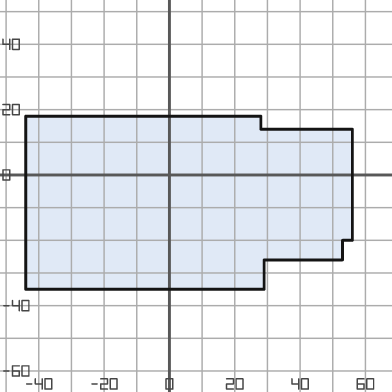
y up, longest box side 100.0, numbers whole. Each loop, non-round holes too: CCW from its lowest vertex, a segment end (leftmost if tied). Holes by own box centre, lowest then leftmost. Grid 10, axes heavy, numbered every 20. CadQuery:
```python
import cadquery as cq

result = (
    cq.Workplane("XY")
    .moveTo(-44.0, -35.0)
    .lineTo(29.0, -35.0)
    .lineTo(29.0, -26.0)
    .lineTo(53.0, -26.0)
    .lineTo(53.0, -20.0)
    .lineTo(56.0, -20.0)
    .lineTo(56.0, 14.0)
    .lineTo(28.0, 14.0)
    .lineTo(28.0, 18.0)
    .lineTo(-44.0, 18.0)
    .close()
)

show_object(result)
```